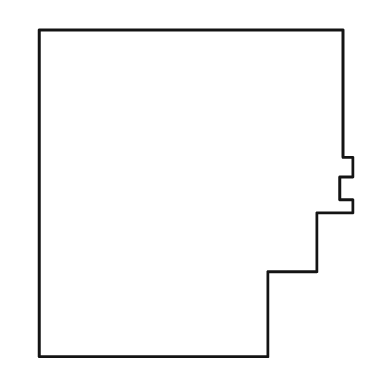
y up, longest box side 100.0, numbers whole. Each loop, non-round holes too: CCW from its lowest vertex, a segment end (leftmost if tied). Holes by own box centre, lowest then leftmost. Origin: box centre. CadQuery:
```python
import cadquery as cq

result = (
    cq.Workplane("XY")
    .moveTo(-48.0, -50.0)
    .lineTo(22.0, -50.0)
    .lineTo(22.0, -24.0)
    .lineTo(37.0, -24.0)
    .lineTo(37.0, -6.0)
    .lineTo(48.0, -6.0)
    .lineTo(48.0, -2.0)
    .lineTo(44.0, -2.0)
    .lineTo(44.0, 5.0)
    .lineTo(48.0, 5.0)
    .lineTo(48.0, 11.0)
    .lineTo(45.0, 11.0)
    .lineTo(45.0, 50.0)
    .lineTo(-48.0, 50.0)
    .close()
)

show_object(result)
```